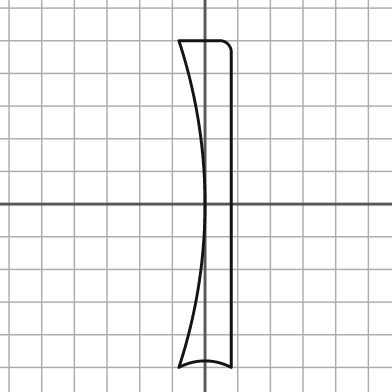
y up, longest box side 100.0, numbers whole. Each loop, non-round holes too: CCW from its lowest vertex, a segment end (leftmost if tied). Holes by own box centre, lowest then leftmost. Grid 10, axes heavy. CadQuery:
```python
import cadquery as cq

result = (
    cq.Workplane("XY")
    .moveTo(-8.0, -50.0)
    .threePointArc((0.0, -48.0), (8.0, -50.0))
    .lineTo(8.0, 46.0)
    .threePointArc((7.0, 49.0), (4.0, 50.0))
    .lineTo(-8.0, 50.0)
    .threePointArc((0.0, 0.0), (-8.0, -50.0))
    .close()
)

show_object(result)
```